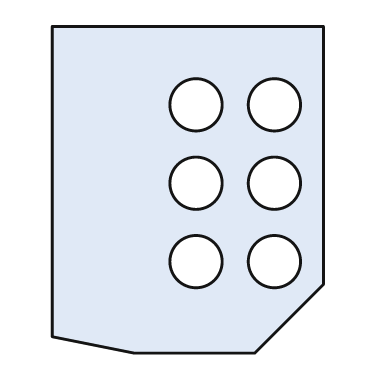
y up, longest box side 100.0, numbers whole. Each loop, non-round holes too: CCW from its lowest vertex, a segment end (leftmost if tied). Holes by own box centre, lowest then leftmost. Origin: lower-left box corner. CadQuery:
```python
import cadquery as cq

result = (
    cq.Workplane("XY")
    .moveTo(25.0, 0.0)
    .lineTo(62.0, 0.0)
    .lineTo(83.0, 21.0)
    .lineTo(83.0, 100.0)
    .lineTo(0.0, 100.0)
    .lineTo(0.0, 5.0)
    .close()
    .moveTo(44.0, 28.0)
    .circle(8.0)
    .moveTo(68.0, 28.0)
    .circle(8.0)
    .moveTo(44.0, 52.0)
    .circle(8.0)
    .moveTo(68.0, 52.0)
    .circle(8.0)
    .moveTo(44.0, 76.0)
    .circle(8.0)
    .moveTo(68.0, 76.0)
    .circle(8.0)
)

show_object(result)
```